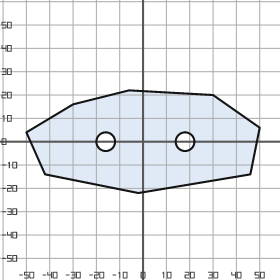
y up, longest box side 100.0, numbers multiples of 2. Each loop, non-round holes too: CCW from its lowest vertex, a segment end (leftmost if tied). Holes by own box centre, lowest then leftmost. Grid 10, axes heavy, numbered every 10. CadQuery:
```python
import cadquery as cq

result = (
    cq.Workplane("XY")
    .moveTo(-2.0, -22.0)
    .lineTo(46.0, -14.0)
    .lineTo(50.0, 6.0)
    .lineTo(30.0, 20.0)
    .lineTo(-6.0, 22.0)
    .lineTo(-30.0, 16.0)
    .lineTo(-50.0, 4.0)
    .lineTo(-42.0, -14.0)
    .close()
    .moveTo(-16.0, 0.0)
    .circle(4.0)
    .moveTo(18.0, 0.0)
    .circle(4.0)
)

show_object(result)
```